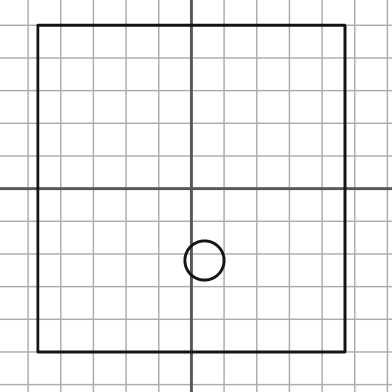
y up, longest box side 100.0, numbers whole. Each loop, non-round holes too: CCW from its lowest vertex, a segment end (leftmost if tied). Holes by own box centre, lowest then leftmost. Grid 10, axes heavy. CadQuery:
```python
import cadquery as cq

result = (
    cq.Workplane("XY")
    .moveTo(-47.0, -50.0)
    .lineTo(47.0, -50.0)
    .lineTo(47.0, 50.0)
    .lineTo(-47.0, 50.0)
    .close()
    .moveTo(4.0, -22.0)
    .circle(6.0)
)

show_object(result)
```